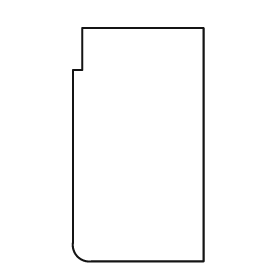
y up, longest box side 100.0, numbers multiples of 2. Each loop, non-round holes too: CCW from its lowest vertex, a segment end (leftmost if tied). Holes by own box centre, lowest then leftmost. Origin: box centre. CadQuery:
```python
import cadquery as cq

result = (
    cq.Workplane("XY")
    .moveTo(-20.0, -50.0)
    .lineTo(28.0, -50.0)
    .lineTo(28.0, 50.0)
    .lineTo(-24.0, 50.0)
    .lineTo(-24.0, 32.0)
    .lineTo(-28.0, 32.0)
    .lineTo(-28.0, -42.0)
    .threePointArc((-26.0, -48.0), (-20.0, -50.0))
    .close()
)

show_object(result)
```